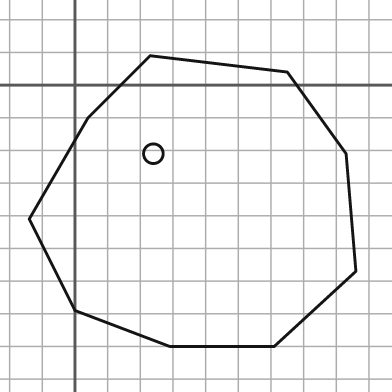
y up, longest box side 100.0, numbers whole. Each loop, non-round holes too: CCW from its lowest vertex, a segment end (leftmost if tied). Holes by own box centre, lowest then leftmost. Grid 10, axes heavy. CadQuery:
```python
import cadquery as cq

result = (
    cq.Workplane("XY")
    .moveTo(29.0, -80.0)
    .lineTo(61.0, -80.0)
    .lineTo(86.0, -57.0)
    .lineTo(83.0, -21.0)
    .lineTo(65.0, 4.0)
    .lineTo(23.0, 9.0)
    .lineTo(4.0, -10.0)
    .lineTo(-14.0, -41.0)
    .lineTo(0.0, -69.0)
    .close()
    .moveTo(24.0, -21.0)
    .circle(3.0)
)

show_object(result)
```